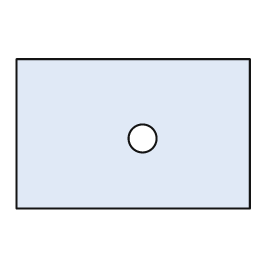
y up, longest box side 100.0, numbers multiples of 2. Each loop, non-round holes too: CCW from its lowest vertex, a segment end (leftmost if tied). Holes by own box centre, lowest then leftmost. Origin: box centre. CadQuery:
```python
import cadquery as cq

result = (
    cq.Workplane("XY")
    .moveTo(-50.0, -32.0)
    .lineTo(50.0, -32.0)
    .lineTo(50.0, 32.0)
    .lineTo(-50.0, 32.0)
    .close()
    .moveTo(4.0, -2.0)
    .circle(6.0)
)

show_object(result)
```